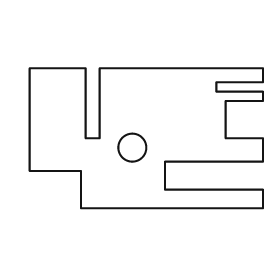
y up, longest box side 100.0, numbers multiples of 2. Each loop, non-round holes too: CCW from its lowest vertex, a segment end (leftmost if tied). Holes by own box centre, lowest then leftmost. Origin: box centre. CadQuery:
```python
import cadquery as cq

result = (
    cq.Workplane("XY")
    .moveTo(-28.0, -30.0)
    .lineTo(50.0, -30.0)
    .lineTo(50.0, -22.0)
    .lineTo(8.0, -22.0)
    .lineTo(8.0, -10.0)
    .lineTo(50.0, -10.0)
    .lineTo(50.0, 0.0)
    .lineTo(34.0, 0.0)
    .lineTo(34.0, 16.0)
    .lineTo(50.0, 16.0)
    .lineTo(50.0, 20.0)
    .lineTo(30.0, 20.0)
    .lineTo(30.0, 24.0)
    .lineTo(50.0, 24.0)
    .lineTo(50.0, 30.0)
    .lineTo(-20.0, 30.0)
    .lineTo(-20.0, 0.0)
    .lineTo(-26.0, 0.0)
    .lineTo(-26.0, 30.0)
    .lineTo(-50.0, 30.0)
    .lineTo(-50.0, -14.0)
    .lineTo(-28.0, -14.0)
    .close()
    .moveTo(-6.0, -4.0)
    .circle(6.0)
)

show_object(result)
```